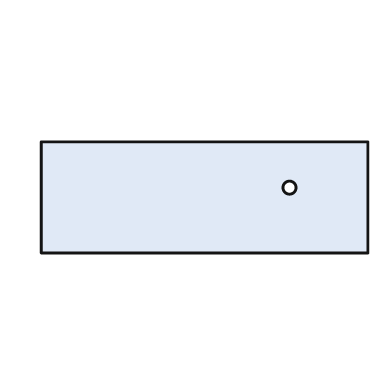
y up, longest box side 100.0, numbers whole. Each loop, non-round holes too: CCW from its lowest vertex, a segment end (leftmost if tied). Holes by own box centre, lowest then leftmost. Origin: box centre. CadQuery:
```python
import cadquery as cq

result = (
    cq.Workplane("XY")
    .moveTo(-50.0, -17.0)
    .lineTo(50.0, -17.0)
    .lineTo(50.0, 17.0)
    .lineTo(-50.0, 17.0)
    .close()
    .moveTo(26.0, 3.0)
    .circle(2.0)
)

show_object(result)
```